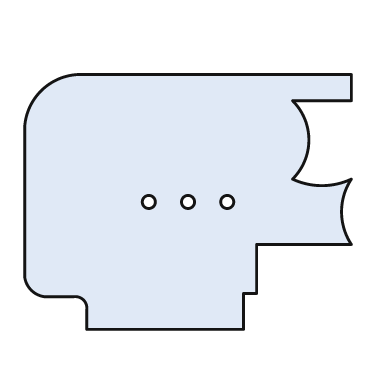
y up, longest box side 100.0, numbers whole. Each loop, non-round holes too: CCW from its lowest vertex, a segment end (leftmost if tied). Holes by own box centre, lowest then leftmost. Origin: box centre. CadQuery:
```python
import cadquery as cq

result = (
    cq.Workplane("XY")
    .moveTo(-31.0, -39.0)
    .lineTo(17.0, -39.0)
    .lineTo(17.0, -28.0)
    .lineTo(21.0, -28.0)
    .lineTo(21.0, -13.0)
    .lineTo(50.0, -13.0)
    .threePointArc((47.0, -3.0), (50.0, 7.0))
    .threePointArc((41.0, 5.0), (32.0, 7.0))
    .threePointArc((37.0, 19.0), (32.0, 31.0))
    .lineTo(50.0, 31.0)
    .lineTo(50.0, 39.0)
    .lineTo(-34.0, 39.0)
    .threePointArc((-45.0, 34.0), (-50.0, 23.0))
    .lineTo(-50.0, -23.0)
    .threePointArc((-48.0, -27.0), (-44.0, -29.0))
    .lineTo(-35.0, -29.0)
    .threePointArc((-32.0, -30.0), (-31.0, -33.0))
    .close()
    .moveTo(-12.0, 0.0)
    .circle(2.0)
    .moveTo(0.0, 0.0)
    .circle(2.0)
    .moveTo(12.0, 0.0)
    .circle(2.0)
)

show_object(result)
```